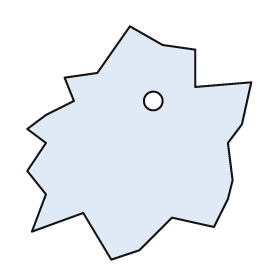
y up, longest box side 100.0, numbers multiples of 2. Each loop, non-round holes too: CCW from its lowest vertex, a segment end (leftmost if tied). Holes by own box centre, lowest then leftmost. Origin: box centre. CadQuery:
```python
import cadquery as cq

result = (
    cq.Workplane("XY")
    .moveTo(-12.0, -50.0)
    .lineTo(0.0, -46.0)
    .lineTo(14.0, -32.0)
    .lineTo(32.0, -36.0)
    .lineTo(38.0, -24.0)
    .lineTo(40.0, -16.0)
    .lineTo(38.0, 0.0)
    .lineTo(44.0, 8.0)
    .lineTo(48.0, 26.0)
    .lineTo(24.0, 24.0)
    .lineTo(24.0, 40.0)
    .lineTo(10.0, 42.0)
    .lineTo(-4.0, 50.0)
    .lineTo(-18.0, 30.0)
    .lineTo(-32.0, 28.0)
    .lineTo(-28.0, 18.0)
    .lineTo(-40.0, 12.0)
    .lineTo(-48.0, 6.0)
    .lineTo(-40.0, 0.0)
    .lineTo(-48.0, -12.0)
    .lineTo(-40.0, -22.0)
    .lineTo(-46.0, -38.0)
    .lineTo(-24.0, -30.0)
    .close()
    .moveTo(6.0, 18.0)
    .circle(4.0)
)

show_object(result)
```